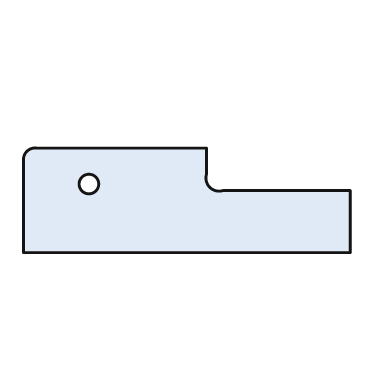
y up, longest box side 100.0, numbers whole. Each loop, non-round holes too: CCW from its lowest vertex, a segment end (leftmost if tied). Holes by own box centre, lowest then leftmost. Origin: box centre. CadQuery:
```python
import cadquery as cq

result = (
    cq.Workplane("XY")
    .moveTo(-50.0, -16.0)
    .lineTo(50.0, -16.0)
    .lineTo(50.0, 3.0)
    .lineTo(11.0, 3.0)
    .threePointArc((7.0, 4.0), (6.0, 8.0))
    .lineTo(6.0, 16.0)
    .lineTo(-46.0, 16.0)
    .threePointArc((-49.0, 15.0), (-50.0, 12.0))
    .close()
    .moveTo(-30.0, 5.0)
    .circle(3.0)
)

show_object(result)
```